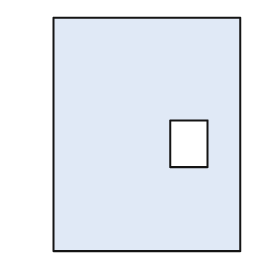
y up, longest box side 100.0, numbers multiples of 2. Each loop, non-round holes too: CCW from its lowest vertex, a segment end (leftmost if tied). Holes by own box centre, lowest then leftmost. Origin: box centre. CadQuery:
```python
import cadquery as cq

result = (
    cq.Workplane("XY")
    .moveTo(-40.0, -50.0)
    .lineTo(40.0, -50.0)
    .lineTo(40.0, 50.0)
    .lineTo(-40.0, 50.0)
    .close()
    .moveTo(10.0, -14.0)
    .lineTo(26.0, -14.0)
    .lineTo(26.0, 6.0)
    .lineTo(10.0, 6.0)
    .close()
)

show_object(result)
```